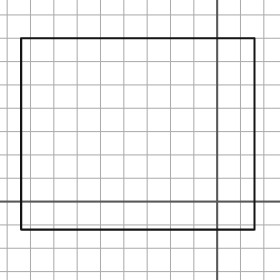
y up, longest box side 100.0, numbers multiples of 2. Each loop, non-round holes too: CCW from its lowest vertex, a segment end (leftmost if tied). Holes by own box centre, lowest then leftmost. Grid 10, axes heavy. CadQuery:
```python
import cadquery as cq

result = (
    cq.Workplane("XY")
    .moveTo(-84.0, -12.0)
    .lineTo(16.0, -12.0)
    .lineTo(16.0, 70.0)
    .lineTo(-84.0, 70.0)
    .close()
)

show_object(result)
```